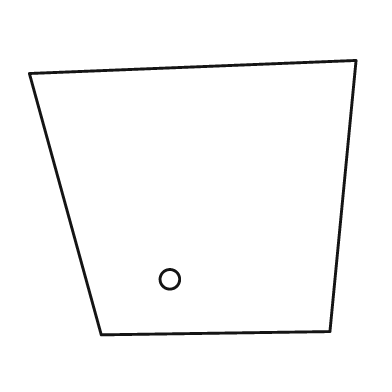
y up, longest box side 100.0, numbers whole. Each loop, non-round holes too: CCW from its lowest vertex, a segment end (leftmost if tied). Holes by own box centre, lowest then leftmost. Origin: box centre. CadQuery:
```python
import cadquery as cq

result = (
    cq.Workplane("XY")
    .moveTo(-28.0, -42.0)
    .lineTo(42.0, -41.0)
    .lineTo(50.0, 42.0)
    .lineTo(-50.0, 38.0)
    .close()
    .moveTo(-7.0, -25.0)
    .circle(3.0)
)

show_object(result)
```